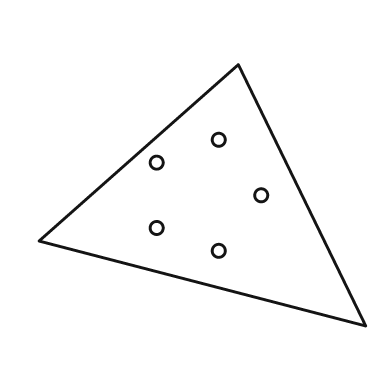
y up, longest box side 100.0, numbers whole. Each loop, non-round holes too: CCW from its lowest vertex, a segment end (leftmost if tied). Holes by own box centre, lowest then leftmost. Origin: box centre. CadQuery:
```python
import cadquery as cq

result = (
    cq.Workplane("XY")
    .moveTo(50.0, -40.0)
    .lineTo(11.0, 40.0)
    .lineTo(-50.0, -14.0)
    .close()
    .moveTo(5.0, -17.0)
    .circle(2.0)
    .moveTo(-14.0, -10.0)
    .circle(2.0)
    .moveTo(18.0, 0.0)
    .circle(2.0)
    .moveTo(-14.0, 10.0)
    .circle(2.0)
    .moveTo(5.0, 17.0)
    .circle(2.0)
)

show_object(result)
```